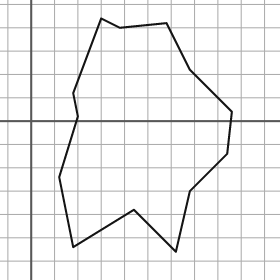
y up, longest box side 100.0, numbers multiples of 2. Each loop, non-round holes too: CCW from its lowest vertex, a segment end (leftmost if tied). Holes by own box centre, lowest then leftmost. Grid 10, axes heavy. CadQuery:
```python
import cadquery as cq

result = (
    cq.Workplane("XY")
    .moveTo(62.0, -56.0)
    .lineTo(68.0, -30.0)
    .lineTo(84.0, -14.0)
    .lineTo(86.0, 4.0)
    .lineTo(68.0, 22.0)
    .lineTo(58.0, 42.0)
    .lineTo(38.0, 40.0)
    .lineTo(30.0, 44.0)
    .lineTo(18.0, 12.0)
    .lineTo(20.0, 2.0)
    .lineTo(12.0, -24.0)
    .lineTo(18.0, -54.0)
    .lineTo(44.0, -38.0)
    .close()
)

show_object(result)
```